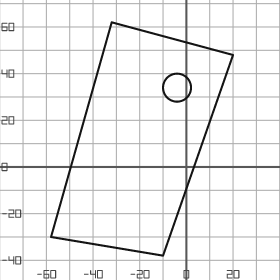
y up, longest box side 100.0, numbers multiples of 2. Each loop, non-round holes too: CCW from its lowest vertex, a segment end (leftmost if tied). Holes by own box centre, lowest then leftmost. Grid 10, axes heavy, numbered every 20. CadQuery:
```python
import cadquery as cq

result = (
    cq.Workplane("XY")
    .moveTo(-10.0, -38.0)
    .lineTo(20.0, 48.0)
    .lineTo(-32.0, 62.0)
    .lineTo(-58.0, -30.0)
    .close()
    .moveTo(-4.0, 34.0)
    .circle(6.0)
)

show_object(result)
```